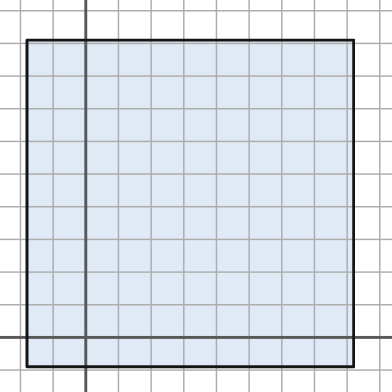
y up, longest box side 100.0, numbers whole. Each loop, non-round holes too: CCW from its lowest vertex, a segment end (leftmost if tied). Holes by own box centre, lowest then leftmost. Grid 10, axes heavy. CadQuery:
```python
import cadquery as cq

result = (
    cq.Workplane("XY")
    .moveTo(-18.0, -9.0)
    .lineTo(82.0, -9.0)
    .lineTo(82.0, 91.0)
    .lineTo(-18.0, 91.0)
    .close()
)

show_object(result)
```